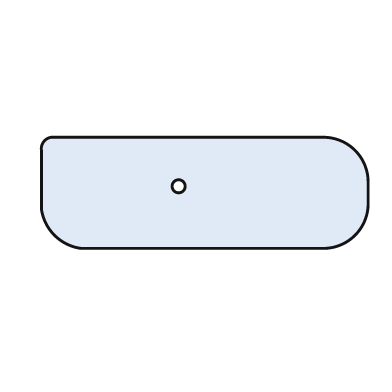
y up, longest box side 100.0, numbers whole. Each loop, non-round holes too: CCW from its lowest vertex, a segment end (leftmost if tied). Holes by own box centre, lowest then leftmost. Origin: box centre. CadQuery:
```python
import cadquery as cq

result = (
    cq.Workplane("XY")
    .moveTo(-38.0, -17.0)
    .lineTo(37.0, -17.0)
    .threePointArc((46.0, -13.0), (50.0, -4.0))
    .lineTo(50.0, 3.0)
    .threePointArc((46.0, 13.0), (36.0, 17.0))
    .lineTo(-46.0, 17.0)
    .threePointArc((-49.0, 16.0), (-50.0, 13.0))
    .lineTo(-50.0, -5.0)
    .threePointArc((-46.0, -13.0), (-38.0, -17.0))
    .close()
    .moveTo(-8.0, 2.0)
    .circle(2.0)
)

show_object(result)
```